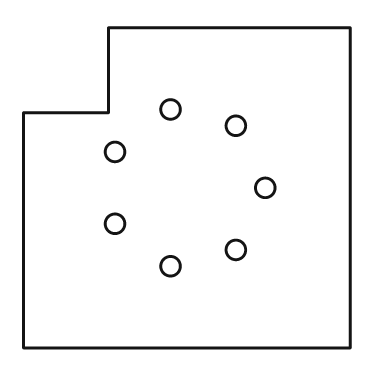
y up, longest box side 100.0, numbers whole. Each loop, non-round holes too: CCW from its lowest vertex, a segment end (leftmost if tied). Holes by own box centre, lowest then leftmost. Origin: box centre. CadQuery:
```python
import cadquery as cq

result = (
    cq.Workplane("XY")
    .moveTo(-50.0, -49.0)
    .lineTo(50.0, -49.0)
    .lineTo(50.0, 49.0)
    .lineTo(-24.0, 49.0)
    .lineTo(-24.0, 23.0)
    .lineTo(-50.0, 23.0)
    .close()
    .moveTo(-5.0, -24.0)
    .circle(3.0)
    .moveTo(15.0, -19.0)
    .circle(3.0)
    .moveTo(-22.0, -11.0)
    .circle(3.0)
    .moveTo(24.0, 0.0)
    .circle(3.0)
    .moveTo(-22.0, 11.0)
    .circle(3.0)
    .moveTo(15.0, 19.0)
    .circle(3.0)
    .moveTo(-5.0, 24.0)
    .circle(3.0)
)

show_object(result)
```